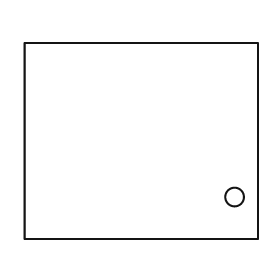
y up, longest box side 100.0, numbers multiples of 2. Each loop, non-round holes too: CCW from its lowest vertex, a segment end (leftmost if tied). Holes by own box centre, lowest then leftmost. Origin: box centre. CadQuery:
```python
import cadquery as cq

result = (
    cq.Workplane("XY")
    .moveTo(-50.0, -42.0)
    .lineTo(50.0, -42.0)
    .lineTo(50.0, 42.0)
    .lineTo(-50.0, 42.0)
    .close()
    .moveTo(40.0, -24.0)
    .circle(4.0)
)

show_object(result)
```